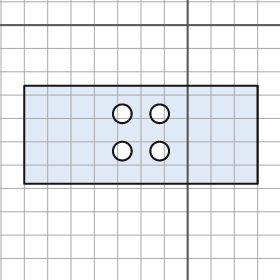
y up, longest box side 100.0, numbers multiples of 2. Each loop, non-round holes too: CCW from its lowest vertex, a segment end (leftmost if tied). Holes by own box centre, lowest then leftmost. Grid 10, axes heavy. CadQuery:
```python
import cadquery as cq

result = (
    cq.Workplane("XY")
    .moveTo(-70.0, -68.0)
    .lineTo(30.0, -68.0)
    .lineTo(30.0, -26.0)
    .lineTo(-70.0, -26.0)
    .close()
    .moveTo(-28.0, -54.0)
    .circle(4.0)
    .moveTo(-12.0, -54.0)
    .circle(4.0)
    .moveTo(-28.0, -38.0)
    .circle(4.0)
    .moveTo(-12.0, -38.0)
    .circle(4.0)
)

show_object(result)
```